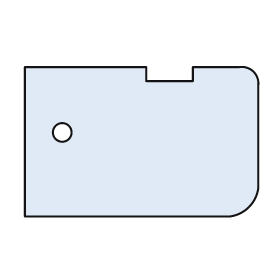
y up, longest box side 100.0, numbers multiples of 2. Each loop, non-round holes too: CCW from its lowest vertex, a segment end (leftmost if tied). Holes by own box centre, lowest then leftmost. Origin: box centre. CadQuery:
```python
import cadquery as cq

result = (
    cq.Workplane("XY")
    .moveTo(-50.0, -32.0)
    .lineTo(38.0, -32.0)
    .threePointArc((46.0, -28.0), (50.0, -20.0))
    .lineTo(50.0, 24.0)
    .threePointArc((48.0, 30.0), (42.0, 32.0))
    .lineTo(22.0, 32.0)
    .lineTo(22.0, 26.0)
    .lineTo(2.0, 26.0)
    .lineTo(2.0, 32.0)
    .lineTo(-50.0, 32.0)
    .close()
    .moveTo(-34.0, 4.0)
    .circle(4.0)
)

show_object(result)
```